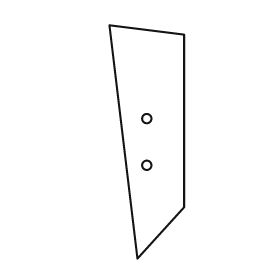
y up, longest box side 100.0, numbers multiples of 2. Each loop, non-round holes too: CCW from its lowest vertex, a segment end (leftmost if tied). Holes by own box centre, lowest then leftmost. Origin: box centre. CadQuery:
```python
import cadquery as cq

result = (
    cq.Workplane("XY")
    .moveTo(-4.0, -50.0)
    .lineTo(16.0, -28.0)
    .lineTo(16.0, 46.0)
    .lineTo(-16.0, 50.0)
    .close()
    .moveTo(0.0, -10.0)
    .circle(2.0)
    .moveTo(0.0, 10.0)
    .circle(2.0)
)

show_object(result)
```